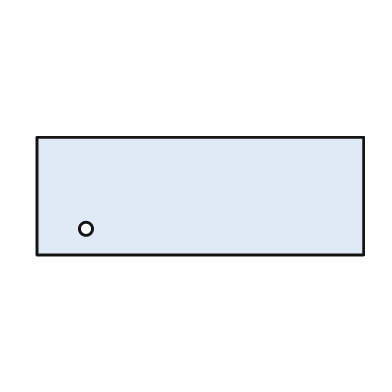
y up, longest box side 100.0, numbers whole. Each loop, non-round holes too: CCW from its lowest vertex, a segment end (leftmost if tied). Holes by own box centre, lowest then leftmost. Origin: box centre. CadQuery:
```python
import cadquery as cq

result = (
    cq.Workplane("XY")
    .moveTo(-50.0, -18.0)
    .lineTo(50.0, -18.0)
    .lineTo(50.0, 18.0)
    .lineTo(-50.0, 18.0)
    .close()
    .moveTo(-35.0, -10.0)
    .circle(2.0)
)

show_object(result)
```